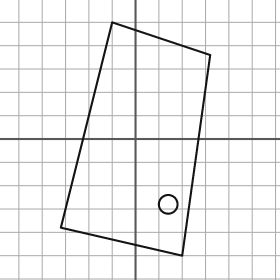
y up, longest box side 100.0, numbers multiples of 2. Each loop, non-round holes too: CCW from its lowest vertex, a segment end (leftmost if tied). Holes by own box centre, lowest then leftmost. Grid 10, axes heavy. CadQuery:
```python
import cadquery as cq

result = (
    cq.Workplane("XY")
    .moveTo(20.0, -50.0)
    .lineTo(32.0, 36.0)
    .lineTo(-10.0, 50.0)
    .lineTo(-32.0, -38.0)
    .close()
    .moveTo(14.0, -28.0)
    .circle(4.0)
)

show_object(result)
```